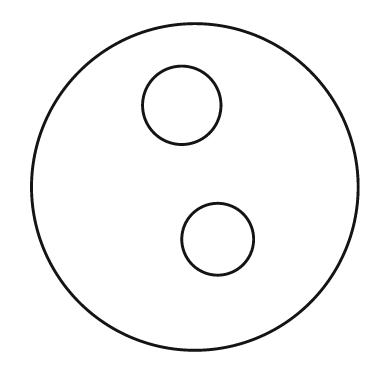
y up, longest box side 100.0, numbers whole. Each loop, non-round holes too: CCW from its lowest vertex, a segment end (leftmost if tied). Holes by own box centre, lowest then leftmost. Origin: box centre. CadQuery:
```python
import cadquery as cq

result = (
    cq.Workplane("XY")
    .moveTo(0.0, 0.0)
    .circle(50.0)
    .moveTo(7.0, -16.0)
    .circle(11.0)
    .moveTo(-4.0, 25.0)
    .circle(12.0)
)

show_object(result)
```